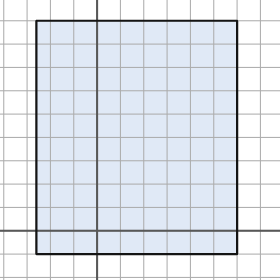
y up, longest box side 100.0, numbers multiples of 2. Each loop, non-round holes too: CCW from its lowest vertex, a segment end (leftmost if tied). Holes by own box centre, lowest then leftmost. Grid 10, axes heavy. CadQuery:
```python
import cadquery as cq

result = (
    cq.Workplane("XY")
    .moveTo(-26.0, -10.0)
    .lineTo(60.0, -10.0)
    .lineTo(60.0, 90.0)
    .lineTo(-26.0, 90.0)
    .close()
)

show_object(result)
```